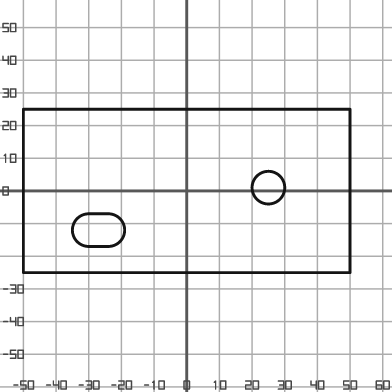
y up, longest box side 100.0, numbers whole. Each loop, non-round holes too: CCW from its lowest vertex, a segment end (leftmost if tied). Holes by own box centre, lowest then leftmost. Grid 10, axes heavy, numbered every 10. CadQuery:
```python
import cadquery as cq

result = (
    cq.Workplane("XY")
    .moveTo(-50.0, -25.0)
    .lineTo(50.0, -25.0)
    .lineTo(50.0, 25.0)
    .lineTo(-50.0, 25.0)
    .close()
    .moveTo(-30.0, -17.0)
    .lineTo(-24.0, -17.0)
    .threePointArc((-19.0, -12.0), (-24.0, -7.0))
    .lineTo(-30.0, -7.0)
    .threePointArc((-35.0, -12.0), (-30.0, -17.0))
    .close()
    .moveTo(25.0, 1.0)
    .circle(5.0)
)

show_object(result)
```